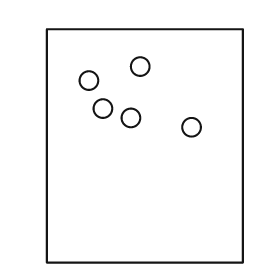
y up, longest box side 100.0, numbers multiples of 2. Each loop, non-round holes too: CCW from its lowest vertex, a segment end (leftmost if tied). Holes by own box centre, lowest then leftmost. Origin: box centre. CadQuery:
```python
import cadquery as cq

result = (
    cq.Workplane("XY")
    .moveTo(-42.0, -50.0)
    .lineTo(42.0, -50.0)
    .lineTo(42.0, 50.0)
    .lineTo(-42.0, 50.0)
    .close()
    .moveTo(20.0, 8.0)
    .circle(4.0)
    .moveTo(-6.0, 12.0)
    .circle(4.0)
    .moveTo(-18.0, 16.0)
    .circle(4.0)
    .moveTo(-24.0, 28.0)
    .circle(4.0)
    .moveTo(-2.0, 34.0)
    .circle(4.0)
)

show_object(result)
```